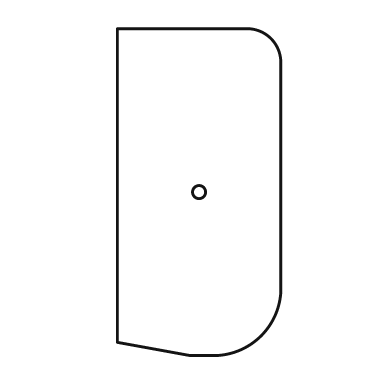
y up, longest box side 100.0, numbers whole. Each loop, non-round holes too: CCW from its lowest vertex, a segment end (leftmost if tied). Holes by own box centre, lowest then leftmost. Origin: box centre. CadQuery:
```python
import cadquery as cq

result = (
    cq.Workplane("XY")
    .moveTo(-3.0, -50.0)
    .lineTo(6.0, -50.0)
    .threePointArc((19.0, -44.0), (25.0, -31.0))
    .lineTo(25.0, 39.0)
    .threePointArc((22.0, 47.0), (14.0, 50.0))
    .lineTo(-25.0, 50.0)
    .lineTo(-25.0, -46.0)
    .close()
    .moveTo(0.0, 0.0)
    .circle(2.0)
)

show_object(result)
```